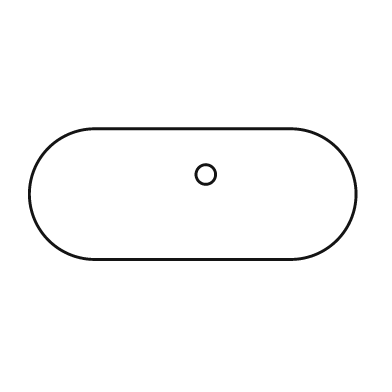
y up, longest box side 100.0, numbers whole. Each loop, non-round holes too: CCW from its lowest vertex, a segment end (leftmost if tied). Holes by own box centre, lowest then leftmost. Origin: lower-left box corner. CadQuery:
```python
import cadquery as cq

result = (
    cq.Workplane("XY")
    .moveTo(20.0, 0.0)
    .lineTo(80.0, 0.0)
    .threePointArc((100.0, 20.0), (80.0, 40.0))
    .lineTo(20.0, 40.0)
    .threePointArc((0.0, 20.0), (20.0, 0.0))
    .close()
    .moveTo(54.0, 26.0)
    .circle(3.0)
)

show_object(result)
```